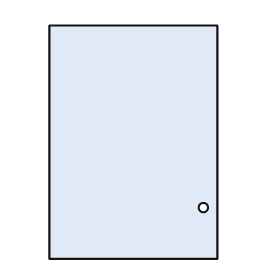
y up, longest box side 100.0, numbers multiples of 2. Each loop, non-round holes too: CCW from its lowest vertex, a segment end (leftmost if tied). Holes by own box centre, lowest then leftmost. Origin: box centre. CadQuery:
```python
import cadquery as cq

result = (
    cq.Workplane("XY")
    .moveTo(-36.0, -50.0)
    .lineTo(36.0, -50.0)
    .lineTo(36.0, 50.0)
    .lineTo(-36.0, 50.0)
    .close()
    .moveTo(30.0, -28.0)
    .circle(2.0)
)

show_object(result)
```